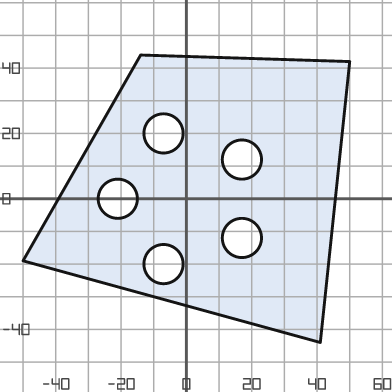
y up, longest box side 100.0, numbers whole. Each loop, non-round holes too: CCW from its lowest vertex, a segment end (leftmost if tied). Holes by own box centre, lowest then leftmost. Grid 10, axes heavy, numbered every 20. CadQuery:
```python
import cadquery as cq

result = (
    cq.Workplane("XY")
    .moveTo(41.0, -44.0)
    .lineTo(50.0, 42.0)
    .lineTo(-14.0, 44.0)
    .lineTo(-50.0, -19.0)
    .close()
    .moveTo(-7.0, -20.0)
    .circle(6.0)
    .moveTo(17.0, -12.0)
    .circle(6.0)
    .moveTo(-21.0, 0.0)
    .circle(6.0)
    .moveTo(17.0, 12.0)
    .circle(6.0)
    .moveTo(-7.0, 20.0)
    .circle(6.0)
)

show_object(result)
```